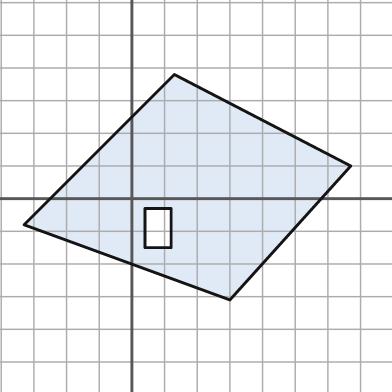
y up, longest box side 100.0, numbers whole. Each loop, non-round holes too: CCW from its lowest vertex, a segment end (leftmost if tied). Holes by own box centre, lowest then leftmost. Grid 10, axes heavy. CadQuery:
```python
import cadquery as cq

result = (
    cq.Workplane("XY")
    .moveTo(30.0, -31.0)
    .lineTo(67.0, 10.0)
    .lineTo(13.0, 38.0)
    .lineTo(-33.0, -8.0)
    .close()
    .moveTo(4.0, -15.0)
    .lineTo(12.0, -15.0)
    .lineTo(12.0, -3.0)
    .lineTo(4.0, -3.0)
    .close()
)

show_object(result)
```